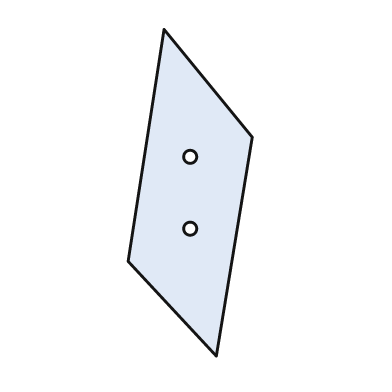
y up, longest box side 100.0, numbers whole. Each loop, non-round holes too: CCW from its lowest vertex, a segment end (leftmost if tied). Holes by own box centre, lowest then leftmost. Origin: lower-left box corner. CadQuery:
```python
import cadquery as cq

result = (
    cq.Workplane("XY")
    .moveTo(27.0, 0.0)
    .lineTo(38.0, 67.0)
    .lineTo(11.0, 100.0)
    .lineTo(0.0, 29.0)
    .close()
    .moveTo(19.0, 39.0)
    .circle(2.0)
    .moveTo(19.0, 61.0)
    .circle(2.0)
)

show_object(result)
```